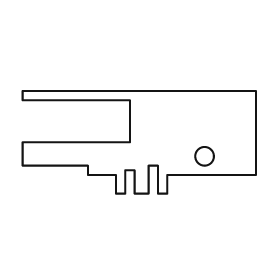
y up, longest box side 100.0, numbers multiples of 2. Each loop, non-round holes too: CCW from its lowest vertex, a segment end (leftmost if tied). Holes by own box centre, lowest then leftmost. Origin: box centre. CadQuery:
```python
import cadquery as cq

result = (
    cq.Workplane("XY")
    .moveTo(-10.0, -22.0)
    .lineTo(-6.0, -22.0)
    .lineTo(-6.0, -12.0)
    .lineTo(-2.0, -12.0)
    .lineTo(-2.0, -22.0)
    .lineTo(4.0, -22.0)
    .lineTo(4.0, -10.0)
    .lineTo(8.0, -10.0)
    .lineTo(8.0, -22.0)
    .lineTo(12.0, -22.0)
    .lineTo(12.0, -14.0)
    .lineTo(50.0, -14.0)
    .lineTo(50.0, 22.0)
    .lineTo(-50.0, 22.0)
    .lineTo(-50.0, 18.0)
    .lineTo(-4.0, 18.0)
    .lineTo(-4.0, 0.0)
    .lineTo(-50.0, 0.0)
    .lineTo(-50.0, -10.0)
    .lineTo(-22.0, -10.0)
    .lineTo(-22.0, -14.0)
    .lineTo(-10.0, -14.0)
    .close()
    .moveTo(28.0, -6.0)
    .circle(4.0)
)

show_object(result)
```